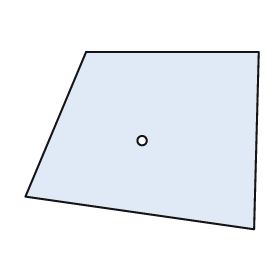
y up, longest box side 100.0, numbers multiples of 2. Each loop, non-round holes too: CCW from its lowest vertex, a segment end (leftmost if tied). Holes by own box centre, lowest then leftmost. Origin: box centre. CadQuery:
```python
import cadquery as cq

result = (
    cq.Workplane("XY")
    .moveTo(48.0, -38.0)
    .lineTo(50.0, 38.0)
    .lineTo(-24.0, 38.0)
    .lineTo(-50.0, -24.0)
    .close()
    .moveTo(0.0, 0.0)
    .circle(2.0)
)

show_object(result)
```